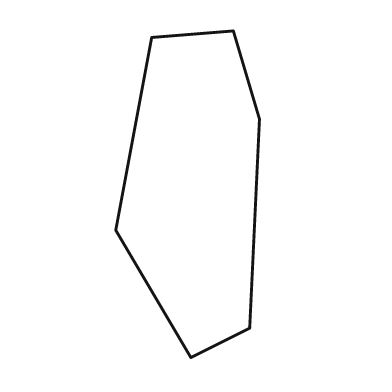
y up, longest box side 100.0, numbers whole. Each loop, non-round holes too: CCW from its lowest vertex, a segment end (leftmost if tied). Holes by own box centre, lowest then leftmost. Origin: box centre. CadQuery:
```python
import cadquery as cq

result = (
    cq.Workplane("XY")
    .moveTo(1.0, -50.0)
    .lineTo(19.0, -41.0)
    .lineTo(22.0, 23.0)
    .lineTo(14.0, 50.0)
    .lineTo(-11.0, 48.0)
    .lineTo(-22.0, -11.0)
    .close()
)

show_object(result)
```